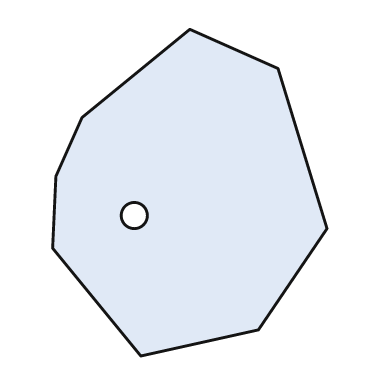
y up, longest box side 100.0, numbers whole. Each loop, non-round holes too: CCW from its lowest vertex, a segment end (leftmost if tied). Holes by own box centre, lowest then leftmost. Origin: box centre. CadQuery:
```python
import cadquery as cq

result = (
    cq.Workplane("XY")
    .moveTo(-15.0, -50.0)
    .lineTo(21.0, -42.0)
    .lineTo(42.0, -11.0)
    .lineTo(27.0, 38.0)
    .lineTo(0.0, 50.0)
    .lineTo(-33.0, 23.0)
    .lineTo(-41.0, 5.0)
    .lineTo(-42.0, -17.0)
    .close()
    .moveTo(-17.0, -7.0)
    .circle(4.0)
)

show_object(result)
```